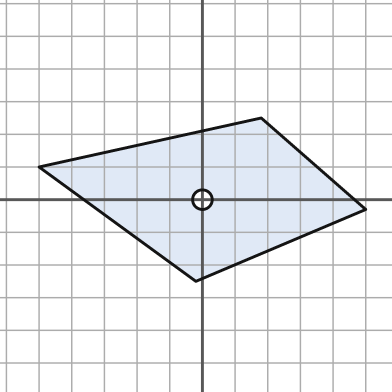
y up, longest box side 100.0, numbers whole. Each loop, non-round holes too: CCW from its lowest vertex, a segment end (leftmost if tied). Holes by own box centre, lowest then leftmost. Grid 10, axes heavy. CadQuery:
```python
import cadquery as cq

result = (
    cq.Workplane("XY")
    .moveTo(-2.0, -25.0)
    .lineTo(50.0, -3.0)
    .lineTo(18.0, 25.0)
    .lineTo(-50.0, 10.0)
    .close()
    .moveTo(0.0, 0.0)
    .circle(3.0)
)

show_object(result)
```